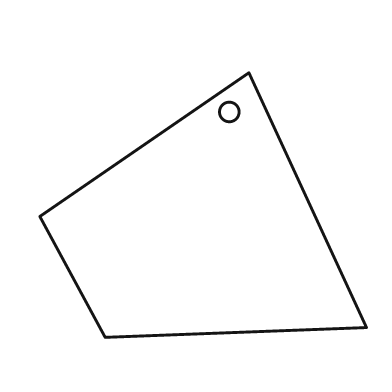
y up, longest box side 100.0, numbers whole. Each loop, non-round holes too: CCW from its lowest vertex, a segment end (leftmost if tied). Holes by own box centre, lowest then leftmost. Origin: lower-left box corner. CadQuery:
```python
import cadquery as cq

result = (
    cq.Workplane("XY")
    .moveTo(20.0, 0.0)
    .lineTo(100.0, 3.0)
    .lineTo(64.0, 81.0)
    .lineTo(0.0, 37.0)
    .close()
    .moveTo(58.0, 69.0)
    .circle(3.0)
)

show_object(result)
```